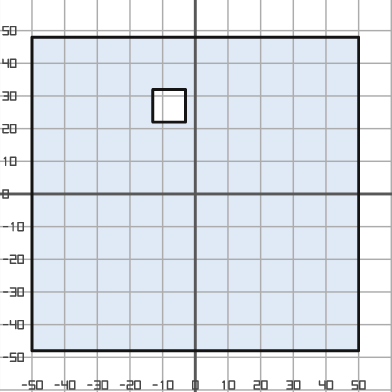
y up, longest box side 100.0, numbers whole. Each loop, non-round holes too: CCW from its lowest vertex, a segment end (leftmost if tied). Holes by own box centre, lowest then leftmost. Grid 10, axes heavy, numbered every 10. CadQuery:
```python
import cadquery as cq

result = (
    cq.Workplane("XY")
    .moveTo(-50.0, -48.0)
    .lineTo(50.0, -48.0)
    .lineTo(50.0, 48.0)
    .lineTo(-50.0, 48.0)
    .close()
    .moveTo(-13.0, 22.0)
    .lineTo(-3.0, 22.0)
    .lineTo(-3.0, 32.0)
    .lineTo(-13.0, 32.0)
    .close()
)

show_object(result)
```